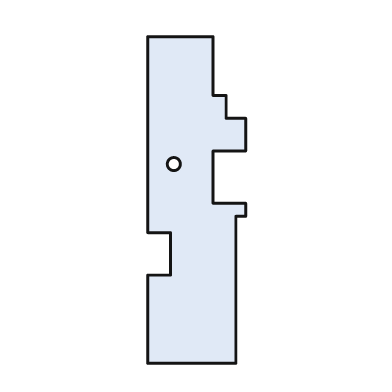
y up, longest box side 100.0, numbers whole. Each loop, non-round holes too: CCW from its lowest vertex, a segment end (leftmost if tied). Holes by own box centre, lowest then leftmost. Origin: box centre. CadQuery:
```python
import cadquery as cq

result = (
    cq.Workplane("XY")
    .moveTo(-15.0, -50.0)
    .lineTo(12.0, -50.0)
    .lineTo(12.0, -5.0)
    .lineTo(15.0, -5.0)
    .lineTo(15.0, -1.0)
    .lineTo(5.0, -1.0)
    .lineTo(5.0, 15.0)
    .lineTo(15.0, 15.0)
    .lineTo(15.0, 25.0)
    .lineTo(9.0, 25.0)
    .lineTo(9.0, 32.0)
    .lineTo(5.0, 32.0)
    .lineTo(5.0, 50.0)
    .lineTo(-15.0, 50.0)
    .lineTo(-15.0, -10.0)
    .lineTo(-8.0, -10.0)
    .lineTo(-8.0, -23.0)
    .lineTo(-15.0, -23.0)
    .close()
    .moveTo(-7.0, 11.0)
    .circle(2.0)
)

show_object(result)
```